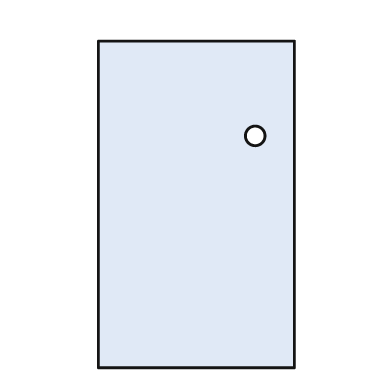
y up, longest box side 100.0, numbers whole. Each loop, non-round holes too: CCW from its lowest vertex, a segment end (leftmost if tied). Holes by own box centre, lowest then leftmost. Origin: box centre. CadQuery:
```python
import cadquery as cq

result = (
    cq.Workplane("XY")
    .moveTo(-30.0, -50.0)
    .lineTo(30.0, -50.0)
    .lineTo(30.0, 50.0)
    .lineTo(-30.0, 50.0)
    .close()
    .moveTo(18.0, 21.0)
    .circle(3.0)
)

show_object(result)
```